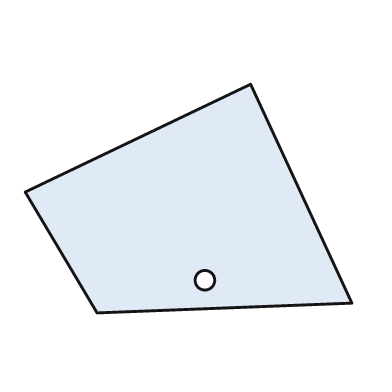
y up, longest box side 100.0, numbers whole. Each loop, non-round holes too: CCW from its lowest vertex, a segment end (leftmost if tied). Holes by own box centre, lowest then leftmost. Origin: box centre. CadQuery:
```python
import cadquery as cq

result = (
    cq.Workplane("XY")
    .moveTo(-28.0, -35.0)
    .lineTo(50.0, -32.0)
    .lineTo(19.0, 35.0)
    .lineTo(-50.0, 2.0)
    .close()
    .moveTo(5.0, -25.0)
    .circle(3.0)
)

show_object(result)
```